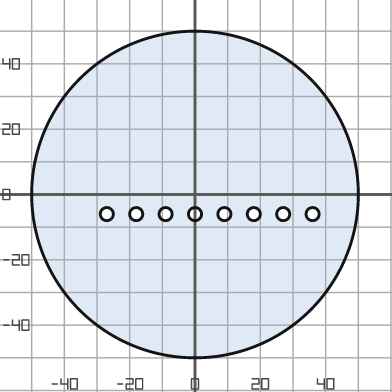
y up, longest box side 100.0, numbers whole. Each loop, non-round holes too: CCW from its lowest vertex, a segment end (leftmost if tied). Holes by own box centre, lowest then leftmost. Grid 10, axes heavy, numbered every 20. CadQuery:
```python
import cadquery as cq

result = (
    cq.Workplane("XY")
    .moveTo(0.0, 0.0)
    .circle(50.0)
    .moveTo(-27.0, -6.0)
    .circle(2.0)
    .moveTo(-18.0, -6.0)
    .circle(2.0)
    .moveTo(-9.0, -6.0)
    .circle(2.0)
    .moveTo(0.0, -6.0)
    .circle(2.0)
    .moveTo(9.0, -6.0)
    .circle(2.0)
    .moveTo(18.0, -6.0)
    .circle(2.0)
    .moveTo(27.0, -6.0)
    .circle(2.0)
    .moveTo(36.0, -6.0)
    .circle(2.0)
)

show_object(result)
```